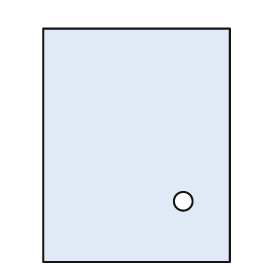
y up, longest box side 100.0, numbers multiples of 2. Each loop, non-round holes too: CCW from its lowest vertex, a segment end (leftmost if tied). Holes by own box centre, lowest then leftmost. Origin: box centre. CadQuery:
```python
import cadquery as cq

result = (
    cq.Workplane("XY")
    .moveTo(-40.0, -50.0)
    .lineTo(40.0, -50.0)
    .lineTo(40.0, 50.0)
    .lineTo(-40.0, 50.0)
    .close()
    .moveTo(20.0, -24.0)
    .circle(4.0)
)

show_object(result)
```